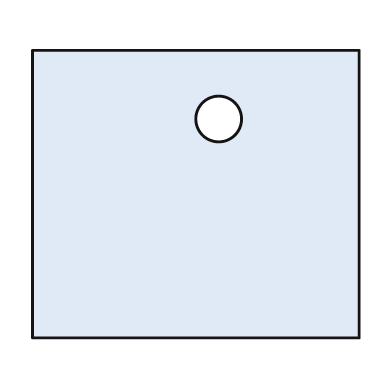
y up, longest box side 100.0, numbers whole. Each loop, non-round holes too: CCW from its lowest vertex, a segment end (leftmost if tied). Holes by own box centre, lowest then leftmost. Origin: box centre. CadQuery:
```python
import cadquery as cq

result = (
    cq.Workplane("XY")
    .moveTo(-50.0, -44.0)
    .lineTo(50.0, -44.0)
    .lineTo(50.0, 44.0)
    .lineTo(-50.0, 44.0)
    .close()
    .moveTo(7.0, 23.0)
    .circle(7.0)
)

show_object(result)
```